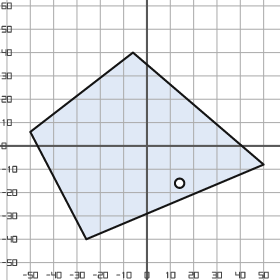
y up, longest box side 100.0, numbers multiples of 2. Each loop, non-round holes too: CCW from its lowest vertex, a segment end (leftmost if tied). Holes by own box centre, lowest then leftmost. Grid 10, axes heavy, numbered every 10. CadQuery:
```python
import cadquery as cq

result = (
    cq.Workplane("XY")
    .moveTo(-26.0, -40.0)
    .lineTo(50.0, -8.0)
    .lineTo(-6.0, 40.0)
    .lineTo(-50.0, 6.0)
    .close()
    .moveTo(14.0, -16.0)
    .circle(2.0)
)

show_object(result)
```